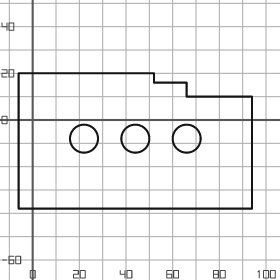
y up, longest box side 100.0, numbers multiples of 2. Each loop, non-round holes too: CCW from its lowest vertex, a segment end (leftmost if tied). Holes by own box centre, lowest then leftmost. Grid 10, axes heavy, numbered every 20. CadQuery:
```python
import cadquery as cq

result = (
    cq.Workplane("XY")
    .moveTo(-6.0, -38.0)
    .lineTo(94.0, -38.0)
    .lineTo(94.0, 10.0)
    .lineTo(66.0, 10.0)
    .lineTo(66.0, 16.0)
    .lineTo(52.0, 16.0)
    .lineTo(52.0, 20.0)
    .lineTo(-6.0, 20.0)
    .close()
    .moveTo(22.0, -8.0)
    .circle(6.0)
    .moveTo(44.0, -8.0)
    .circle(6.0)
    .moveTo(66.0, -8.0)
    .circle(6.0)
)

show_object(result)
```